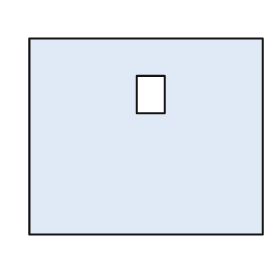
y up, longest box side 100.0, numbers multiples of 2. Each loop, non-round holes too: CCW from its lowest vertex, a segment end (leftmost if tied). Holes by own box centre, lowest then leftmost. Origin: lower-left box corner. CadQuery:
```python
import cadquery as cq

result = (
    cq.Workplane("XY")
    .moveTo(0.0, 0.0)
    .lineTo(100.0, 0.0)
    .lineTo(100.0, 84.0)
    .lineTo(0.0, 84.0)
    .close()
    .moveTo(46.0, 52.0)
    .lineTo(58.0, 52.0)
    .lineTo(58.0, 68.0)
    .lineTo(46.0, 68.0)
    .close()
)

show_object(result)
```